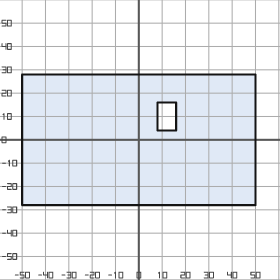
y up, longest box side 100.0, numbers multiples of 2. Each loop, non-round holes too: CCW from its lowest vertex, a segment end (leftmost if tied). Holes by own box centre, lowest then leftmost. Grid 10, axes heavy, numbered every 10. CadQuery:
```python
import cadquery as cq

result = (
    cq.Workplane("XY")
    .moveTo(-50.0, -28.0)
    .lineTo(50.0, -28.0)
    .lineTo(50.0, 28.0)
    .lineTo(-50.0, 28.0)
    .close()
    .moveTo(8.0, 4.0)
    .lineTo(16.0, 4.0)
    .lineTo(16.0, 16.0)
    .lineTo(8.0, 16.0)
    .close()
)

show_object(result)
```